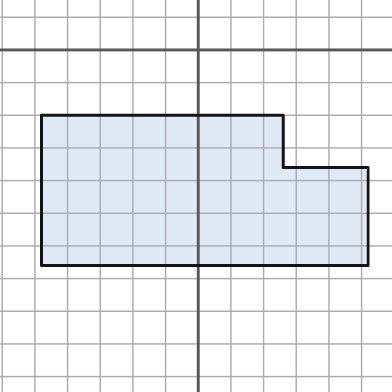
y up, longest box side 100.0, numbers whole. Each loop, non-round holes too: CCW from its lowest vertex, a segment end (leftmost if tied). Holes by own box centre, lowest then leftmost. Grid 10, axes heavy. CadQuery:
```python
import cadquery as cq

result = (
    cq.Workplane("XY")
    .moveTo(-48.0, -66.0)
    .lineTo(52.0, -66.0)
    .lineTo(52.0, -36.0)
    .lineTo(26.0, -36.0)
    .lineTo(26.0, -20.0)
    .lineTo(-48.0, -20.0)
    .close()
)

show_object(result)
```